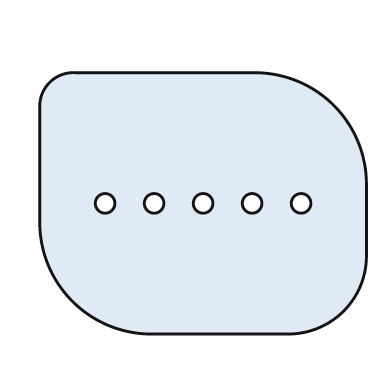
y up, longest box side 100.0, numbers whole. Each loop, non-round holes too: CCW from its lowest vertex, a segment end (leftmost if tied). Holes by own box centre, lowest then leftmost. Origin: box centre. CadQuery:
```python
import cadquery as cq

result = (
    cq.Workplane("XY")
    .moveTo(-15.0, -40.0)
    .lineTo(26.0, -40.0)
    .threePointArc((43.0, -33.0), (50.0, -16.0))
    .lineTo(50.0, 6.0)
    .threePointArc((40.0, 30.0), (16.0, 40.0))
    .lineTo(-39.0, 40.0)
    .threePointArc((-47.0, 37.0), (-50.0, 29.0))
    .lineTo(-50.0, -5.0)
    .threePointArc((-40.0, -30.0), (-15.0, -40.0))
    .close()
    .moveTo(-30.0, 0.0)
    .circle(3.0)
    .moveTo(-15.0, 0.0)
    .circle(3.0)
    .moveTo(0.0, 0.0)
    .circle(3.0)
    .moveTo(15.0, 0.0)
    .circle(3.0)
    .moveTo(30.0, 0.0)
    .circle(3.0)
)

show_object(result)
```